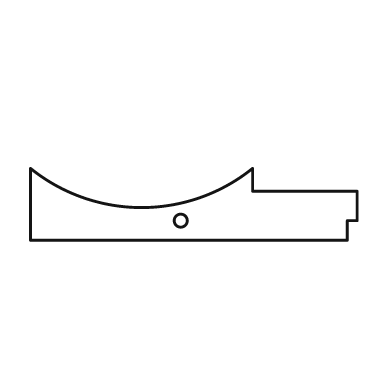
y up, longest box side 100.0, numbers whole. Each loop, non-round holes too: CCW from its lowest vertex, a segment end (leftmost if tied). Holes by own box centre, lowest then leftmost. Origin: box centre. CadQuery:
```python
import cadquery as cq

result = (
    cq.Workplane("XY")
    .moveTo(-50.0, -11.0)
    .lineTo(47.0, -11.0)
    .lineTo(47.0, -5.0)
    .lineTo(50.0, -5.0)
    .lineTo(50.0, 4.0)
    .lineTo(18.0, 4.0)
    .lineTo(18.0, 11.0)
    .threePointArc((-16.0, -1.0), (-50.0, 11.0))
    .close()
    .moveTo(-4.0, -5.0)
    .circle(2.0)
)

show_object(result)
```